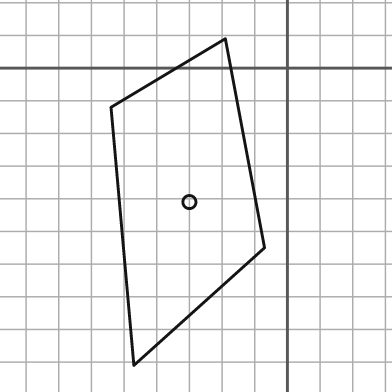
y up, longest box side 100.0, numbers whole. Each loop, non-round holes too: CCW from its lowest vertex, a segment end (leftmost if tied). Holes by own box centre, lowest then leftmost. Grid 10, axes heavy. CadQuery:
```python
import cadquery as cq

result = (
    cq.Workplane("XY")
    .moveTo(-47.0, -91.0)
    .lineTo(-7.0, -55.0)
    .lineTo(-19.0, 9.0)
    .lineTo(-54.0, -12.0)
    .close()
    .moveTo(-30.0, -41.0)
    .circle(2.0)
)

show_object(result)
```